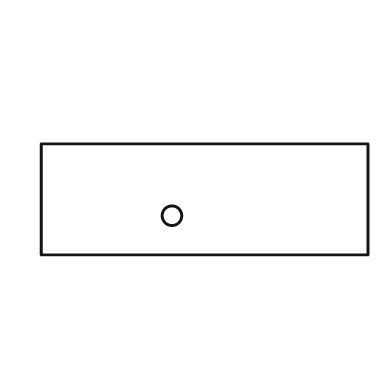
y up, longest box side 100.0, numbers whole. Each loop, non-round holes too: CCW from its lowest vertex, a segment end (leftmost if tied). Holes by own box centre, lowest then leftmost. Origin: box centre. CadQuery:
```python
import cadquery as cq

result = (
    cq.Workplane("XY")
    .moveTo(-50.0, -17.0)
    .lineTo(50.0, -17.0)
    .lineTo(50.0, 17.0)
    .lineTo(-50.0, 17.0)
    .close()
    .moveTo(-10.0, -5.0)
    .circle(3.0)
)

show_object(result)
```